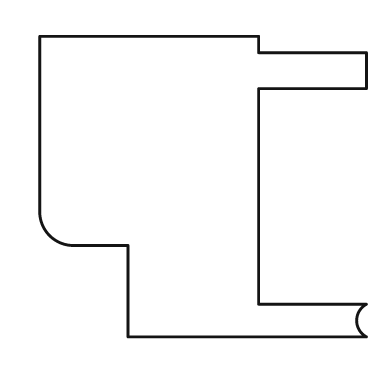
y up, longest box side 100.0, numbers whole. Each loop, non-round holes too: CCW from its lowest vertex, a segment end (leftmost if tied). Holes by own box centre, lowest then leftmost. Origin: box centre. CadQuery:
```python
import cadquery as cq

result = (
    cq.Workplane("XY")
    .moveTo(-23.0, -46.0)
    .lineTo(50.0, -46.0)
    .threePointArc((47.0, -41.0), (50.0, -36.0))
    .lineTo(17.0, -36.0)
    .lineTo(17.0, 30.0)
    .lineTo(50.0, 30.0)
    .lineTo(50.0, 41.0)
    .lineTo(17.0, 41.0)
    .lineTo(17.0, 46.0)
    .lineTo(-50.0, 46.0)
    .lineTo(-50.0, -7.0)
    .threePointArc((-47.0, -15.0), (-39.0, -18.0))
    .lineTo(-23.0, -18.0)
    .close()
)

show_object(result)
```